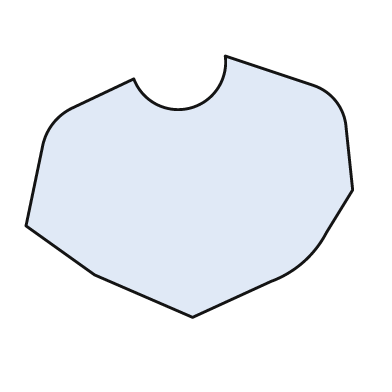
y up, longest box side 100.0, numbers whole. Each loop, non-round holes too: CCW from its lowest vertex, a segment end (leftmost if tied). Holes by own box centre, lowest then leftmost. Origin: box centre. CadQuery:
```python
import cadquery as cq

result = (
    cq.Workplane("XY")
    .moveTo(1.0, -40.0)
    .lineTo(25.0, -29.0)
    .threePointArc((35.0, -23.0), (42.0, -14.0))
    .lineTo(50.0, -1.0)
    .lineTo(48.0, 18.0)
    .threePointArc((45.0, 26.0), (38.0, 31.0))
    .lineTo(11.0, 40.0)
    .threePointArc((0.0, 24.0), (-17.0, 33.0))
    .lineTo(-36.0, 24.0)
    .threePointArc((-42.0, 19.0), (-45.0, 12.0))
    .lineTo(-50.0, -12.0)
    .lineTo(-29.0, -27.0)
    .close()
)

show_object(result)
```